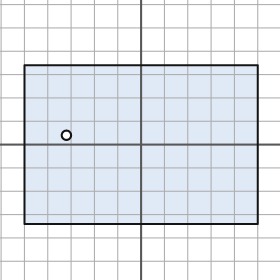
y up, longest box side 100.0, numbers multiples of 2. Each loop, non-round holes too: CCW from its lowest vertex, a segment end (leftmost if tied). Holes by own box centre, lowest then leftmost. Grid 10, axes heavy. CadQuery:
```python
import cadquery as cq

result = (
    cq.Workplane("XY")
    .moveTo(-50.0, -34.0)
    .lineTo(50.0, -34.0)
    .lineTo(50.0, 34.0)
    .lineTo(-50.0, 34.0)
    .close()
    .moveTo(-32.0, 4.0)
    .circle(2.0)
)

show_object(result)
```